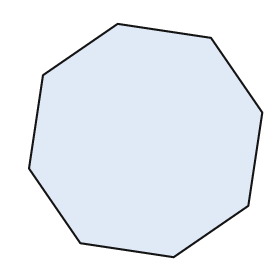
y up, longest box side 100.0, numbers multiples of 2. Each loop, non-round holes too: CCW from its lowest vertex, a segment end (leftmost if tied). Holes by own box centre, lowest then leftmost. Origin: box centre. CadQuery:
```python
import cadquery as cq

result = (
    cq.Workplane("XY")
    .moveTo(12.0, -50.0)
    .lineTo(44.0, -28.0)
    .lineTo(50.0, 12.0)
    .lineTo(28.0, 44.0)
    .lineTo(-12.0, 50.0)
    .lineTo(-44.0, 28.0)
    .lineTo(-50.0, -12.0)
    .lineTo(-28.0, -44.0)
    .close()
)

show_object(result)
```